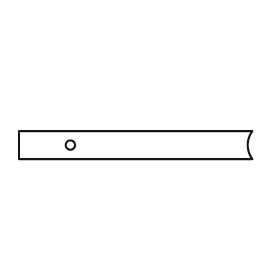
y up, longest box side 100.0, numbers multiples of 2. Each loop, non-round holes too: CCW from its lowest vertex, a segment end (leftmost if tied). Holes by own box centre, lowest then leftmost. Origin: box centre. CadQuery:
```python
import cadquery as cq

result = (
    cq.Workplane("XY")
    .moveTo(-50.0, -6.0)
    .lineTo(50.0, -6.0)
    .threePointArc((48.0, 0.0), (50.0, 6.0))
    .lineTo(-50.0, 6.0)
    .close()
    .moveTo(-28.0, 0.0)
    .circle(2.0)
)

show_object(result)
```